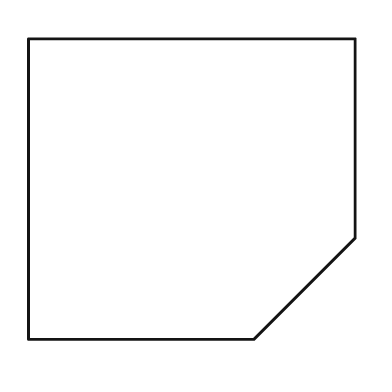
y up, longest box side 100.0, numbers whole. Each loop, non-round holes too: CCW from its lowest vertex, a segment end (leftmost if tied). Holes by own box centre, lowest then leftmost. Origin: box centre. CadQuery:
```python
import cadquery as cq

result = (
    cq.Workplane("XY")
    .moveTo(-50.0, -46.0)
    .lineTo(19.0, -46.0)
    .lineTo(50.0, -15.0)
    .lineTo(50.0, 46.0)
    .lineTo(-50.0, 46.0)
    .close()
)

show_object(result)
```